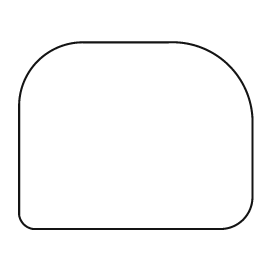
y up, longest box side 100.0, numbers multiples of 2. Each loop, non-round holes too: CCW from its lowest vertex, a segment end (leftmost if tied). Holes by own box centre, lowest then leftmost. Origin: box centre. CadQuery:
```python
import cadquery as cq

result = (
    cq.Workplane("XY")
    .moveTo(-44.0, -40.0)
    .lineTo(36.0, -40.0)
    .threePointArc((46.0, -36.0), (50.0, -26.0))
    .lineTo(50.0, 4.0)
    .threePointArc((40.0, 30.0), (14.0, 40.0))
    .lineTo(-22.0, 40.0)
    .threePointArc((-42.0, 32.0), (-50.0, 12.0))
    .lineTo(-50.0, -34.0)
    .threePointArc((-48.0, -38.0), (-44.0, -40.0))
    .close()
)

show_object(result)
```